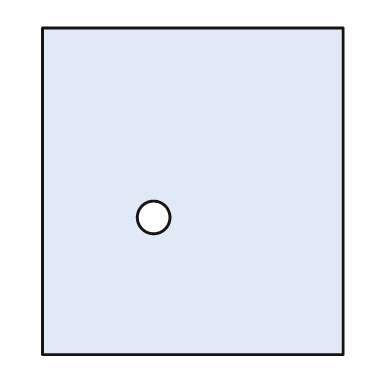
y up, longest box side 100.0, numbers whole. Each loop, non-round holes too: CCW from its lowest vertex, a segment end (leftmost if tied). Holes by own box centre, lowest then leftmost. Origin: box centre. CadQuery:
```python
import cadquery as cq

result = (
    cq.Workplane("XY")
    .moveTo(-46.0, -50.0)
    .lineTo(46.0, -50.0)
    .lineTo(46.0, 50.0)
    .lineTo(-46.0, 50.0)
    .close()
    .moveTo(-12.0, -8.0)
    .circle(5.0)
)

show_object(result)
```